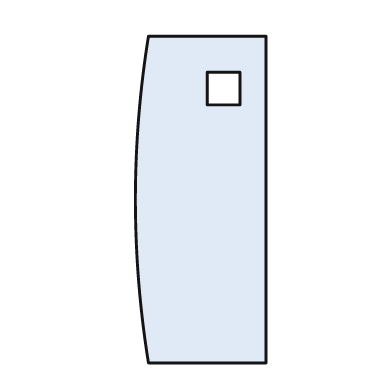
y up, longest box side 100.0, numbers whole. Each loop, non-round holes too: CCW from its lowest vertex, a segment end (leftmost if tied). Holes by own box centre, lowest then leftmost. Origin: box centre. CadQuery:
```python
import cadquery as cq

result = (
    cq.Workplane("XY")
    .moveTo(-16.0, -50.0)
    .lineTo(20.0, -50.0)
    .lineTo(20.0, 50.0)
    .lineTo(-16.0, 50.0)
    .threePointArc((-20.0, 0.0), (-16.0, -50.0))
    .close()
    .moveTo(2.0, 29.0)
    .lineTo(12.0, 29.0)
    .lineTo(12.0, 39.0)
    .lineTo(2.0, 39.0)
    .close()
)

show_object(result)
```